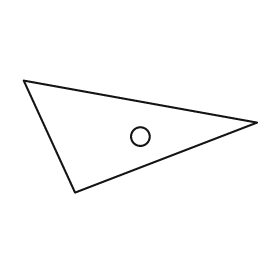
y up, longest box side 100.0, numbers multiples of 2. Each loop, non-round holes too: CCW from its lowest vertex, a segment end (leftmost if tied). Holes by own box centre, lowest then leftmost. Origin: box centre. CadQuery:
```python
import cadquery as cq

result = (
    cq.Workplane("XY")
    .moveTo(-28.0, -24.0)
    .lineTo(50.0, 6.0)
    .lineTo(-50.0, 24.0)
    .close()
    .moveTo(0.0, 0.0)
    .circle(4.0)
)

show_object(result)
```